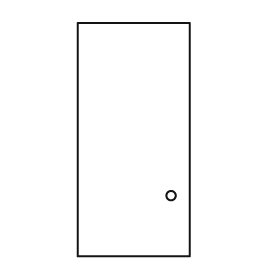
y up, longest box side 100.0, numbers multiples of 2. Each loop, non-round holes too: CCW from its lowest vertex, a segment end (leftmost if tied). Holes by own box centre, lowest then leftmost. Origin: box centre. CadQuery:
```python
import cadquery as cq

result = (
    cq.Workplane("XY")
    .moveTo(-24.0, -50.0)
    .lineTo(24.0, -50.0)
    .lineTo(24.0, 50.0)
    .lineTo(-24.0, 50.0)
    .close()
    .moveTo(16.0, -24.0)
    .circle(2.0)
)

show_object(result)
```